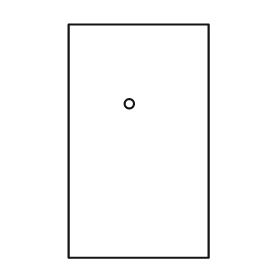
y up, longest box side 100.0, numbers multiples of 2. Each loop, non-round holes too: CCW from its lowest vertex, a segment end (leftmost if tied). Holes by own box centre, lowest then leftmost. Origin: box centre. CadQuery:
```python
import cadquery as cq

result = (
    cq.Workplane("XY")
    .moveTo(-30.0, -50.0)
    .lineTo(30.0, -50.0)
    .lineTo(30.0, 50.0)
    .lineTo(-30.0, 50.0)
    .close()
    .moveTo(-4.0, 16.0)
    .circle(2.0)
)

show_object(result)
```